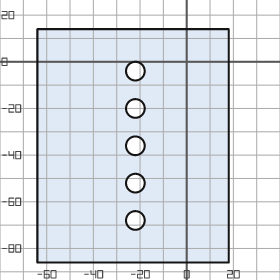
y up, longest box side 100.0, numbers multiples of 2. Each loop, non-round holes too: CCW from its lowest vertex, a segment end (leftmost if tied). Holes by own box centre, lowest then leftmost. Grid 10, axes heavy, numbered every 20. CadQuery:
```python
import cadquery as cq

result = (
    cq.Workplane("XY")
    .moveTo(-64.0, -86.0)
    .lineTo(18.0, -86.0)
    .lineTo(18.0, 14.0)
    .lineTo(-64.0, 14.0)
    .close()
    .moveTo(-22.0, -68.0)
    .circle(4.0)
    .moveTo(-22.0, -52.0)
    .circle(4.0)
    .moveTo(-22.0, -36.0)
    .circle(4.0)
    .moveTo(-22.0, -20.0)
    .circle(4.0)
    .moveTo(-22.0, -4.0)
    .circle(4.0)
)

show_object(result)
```